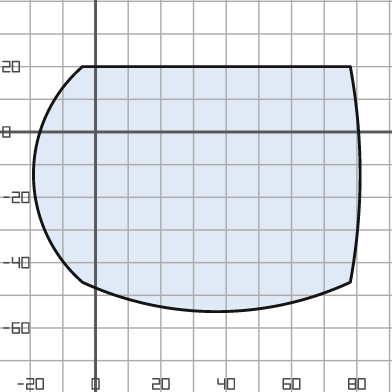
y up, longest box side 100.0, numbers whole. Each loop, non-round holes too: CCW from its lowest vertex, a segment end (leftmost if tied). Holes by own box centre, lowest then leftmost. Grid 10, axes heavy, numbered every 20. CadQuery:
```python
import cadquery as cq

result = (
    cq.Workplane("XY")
    .moveTo(-4.0, -46.0)
    .threePointArc((37.0, -55.0), (78.0, -46.0))
    .threePointArc((81.0, -13.0), (78.0, 20.0))
    .lineTo(-4.0, 20.0)
    .threePointArc((-19.0, -13.0), (-4.0, -46.0))
    .close()
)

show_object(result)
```